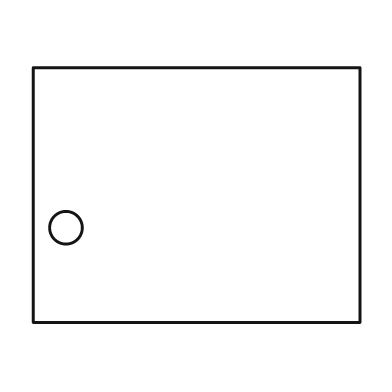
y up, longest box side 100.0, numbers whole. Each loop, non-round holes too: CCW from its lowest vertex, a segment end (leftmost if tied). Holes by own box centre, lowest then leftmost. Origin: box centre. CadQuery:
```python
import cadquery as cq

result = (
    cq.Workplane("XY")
    .moveTo(-50.0, -39.0)
    .lineTo(50.0, -39.0)
    .lineTo(50.0, 39.0)
    .lineTo(-50.0, 39.0)
    .close()
    .moveTo(-40.0, -10.0)
    .circle(5.0)
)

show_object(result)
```